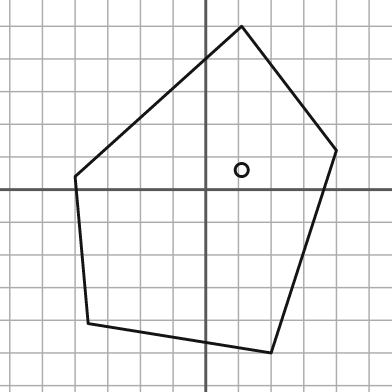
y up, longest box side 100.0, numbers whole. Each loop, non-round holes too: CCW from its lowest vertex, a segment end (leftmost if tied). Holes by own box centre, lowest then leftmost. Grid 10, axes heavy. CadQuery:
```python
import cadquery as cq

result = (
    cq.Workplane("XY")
    .moveTo(20.0, -50.0)
    .lineTo(40.0, 12.0)
    .lineTo(11.0, 50.0)
    .lineTo(-40.0, 4.0)
    .lineTo(-36.0, -41.0)
    .close()
    .moveTo(11.0, 6.0)
    .circle(2.0)
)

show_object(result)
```